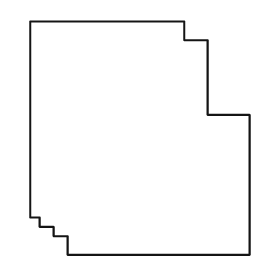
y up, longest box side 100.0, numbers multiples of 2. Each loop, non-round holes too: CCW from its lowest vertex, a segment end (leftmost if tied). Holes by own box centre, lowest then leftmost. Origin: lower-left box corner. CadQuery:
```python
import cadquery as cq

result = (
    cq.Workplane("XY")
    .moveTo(16.0, 0.0)
    .lineTo(94.0, 0.0)
    .lineTo(94.0, 60.0)
    .lineTo(76.0, 60.0)
    .lineTo(76.0, 92.0)
    .lineTo(66.0, 92.0)
    .lineTo(66.0, 100.0)
    .lineTo(0.0, 100.0)
    .lineTo(0.0, 16.0)
    .lineTo(4.0, 16.0)
    .lineTo(4.0, 12.0)
    .lineTo(10.0, 12.0)
    .lineTo(10.0, 8.0)
    .lineTo(16.0, 8.0)
    .close()
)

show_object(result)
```